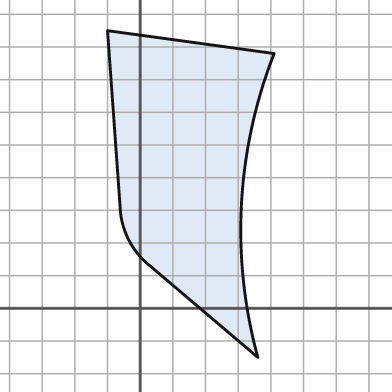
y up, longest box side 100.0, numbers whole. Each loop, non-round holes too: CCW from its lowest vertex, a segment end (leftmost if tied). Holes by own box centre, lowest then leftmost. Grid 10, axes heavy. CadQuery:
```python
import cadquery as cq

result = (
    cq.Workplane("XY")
    .moveTo(36.0, -15.0)
    .threePointArc((31.0, 32.0), (41.0, 78.0))
    .lineTo(-10.0, 85.0)
    .lineTo(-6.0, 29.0)
    .threePointArc((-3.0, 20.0), (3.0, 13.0))
    .close()
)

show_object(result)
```